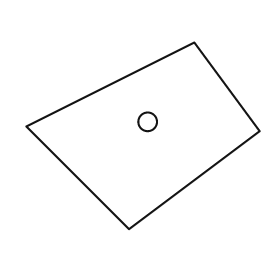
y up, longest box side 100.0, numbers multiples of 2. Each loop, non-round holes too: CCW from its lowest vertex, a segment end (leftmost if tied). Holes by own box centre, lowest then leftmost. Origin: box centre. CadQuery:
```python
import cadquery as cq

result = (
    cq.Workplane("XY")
    .moveTo(-6.0, -40.0)
    .lineTo(50.0, 2.0)
    .lineTo(22.0, 40.0)
    .lineTo(-50.0, 4.0)
    .close()
    .moveTo(2.0, 6.0)
    .circle(4.0)
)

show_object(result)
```